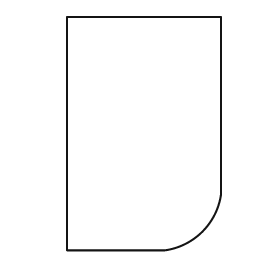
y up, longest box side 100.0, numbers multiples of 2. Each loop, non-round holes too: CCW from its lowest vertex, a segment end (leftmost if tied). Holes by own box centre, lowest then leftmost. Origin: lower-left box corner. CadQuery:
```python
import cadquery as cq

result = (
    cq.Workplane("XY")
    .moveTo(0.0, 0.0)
    .lineTo(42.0, 0.0)
    .threePointArc((58.0, 8.0), (66.0, 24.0))
    .lineTo(66.0, 100.0)
    .lineTo(0.0, 100.0)
    .close()
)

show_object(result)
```